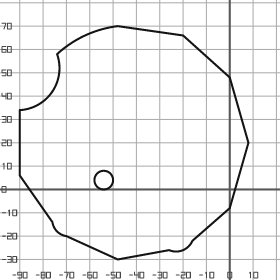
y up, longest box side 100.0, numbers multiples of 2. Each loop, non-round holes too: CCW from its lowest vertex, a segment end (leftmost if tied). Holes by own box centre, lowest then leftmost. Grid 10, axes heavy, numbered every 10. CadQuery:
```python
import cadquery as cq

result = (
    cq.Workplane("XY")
    .moveTo(-48.0, -30.0)
    .lineTo(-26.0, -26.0)
    .threePointArc((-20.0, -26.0), (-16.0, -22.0))
    .lineTo(0.0, -8.0)
    .lineTo(8.0, 20.0)
    .lineTo(0.0, 48.0)
    .lineTo(-20.0, 66.0)
    .lineTo(-48.0, 70.0)
    .threePointArc((-62.0, 66.0), (-74.0, 58.0))
    .threePointArc((-76.0, 42.0), (-90.0, 34.0))
    .lineTo(-90.0, 6.0)
    .lineTo(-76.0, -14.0)
    .threePointArc((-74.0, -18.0), (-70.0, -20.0))
    .close()
    .moveTo(-54.0, 4.0)
    .circle(4.0)
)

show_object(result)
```